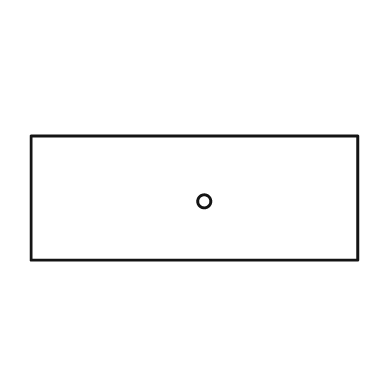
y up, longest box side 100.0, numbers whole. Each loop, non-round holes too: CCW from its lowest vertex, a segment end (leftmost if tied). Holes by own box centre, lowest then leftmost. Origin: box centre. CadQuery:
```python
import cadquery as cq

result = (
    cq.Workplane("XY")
    .moveTo(-50.0, -19.0)
    .lineTo(50.0, -19.0)
    .lineTo(50.0, 19.0)
    .lineTo(-50.0, 19.0)
    .close()
    .moveTo(3.0, -1.0)
    .circle(2.0)
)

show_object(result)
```